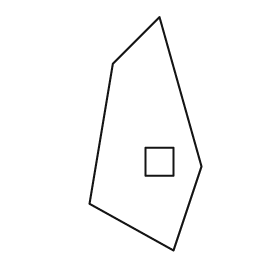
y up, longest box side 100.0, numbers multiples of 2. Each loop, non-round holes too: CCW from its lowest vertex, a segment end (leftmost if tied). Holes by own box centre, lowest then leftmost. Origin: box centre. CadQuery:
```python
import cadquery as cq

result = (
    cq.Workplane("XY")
    .moveTo(12.0, -50.0)
    .lineTo(24.0, -14.0)
    .lineTo(6.0, 50.0)
    .lineTo(-14.0, 30.0)
    .lineTo(-24.0, -30.0)
    .close()
    .moveTo(0.0, -18.0)
    .lineTo(12.0, -18.0)
    .lineTo(12.0, -6.0)
    .lineTo(0.0, -6.0)
    .close()
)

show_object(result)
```